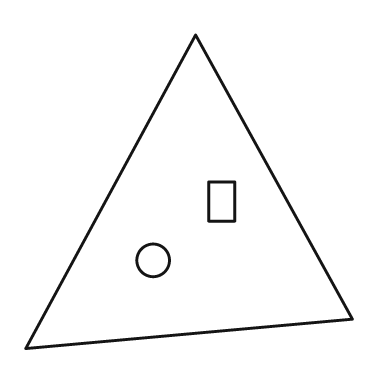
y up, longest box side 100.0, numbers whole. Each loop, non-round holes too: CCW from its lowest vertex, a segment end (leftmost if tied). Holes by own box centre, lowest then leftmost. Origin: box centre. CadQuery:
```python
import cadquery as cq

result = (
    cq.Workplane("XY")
    .moveTo(-50.0, -48.0)
    .lineTo(50.0, -39.0)
    .lineTo(2.0, 48.0)
    .close()
    .moveTo(-11.0, -21.0)
    .circle(5.0)
    .moveTo(6.0, -9.0)
    .lineTo(14.0, -9.0)
    .lineTo(14.0, 3.0)
    .lineTo(6.0, 3.0)
    .close()
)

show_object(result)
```